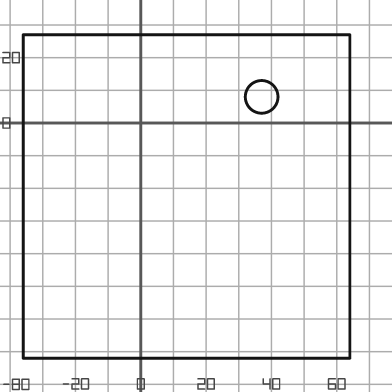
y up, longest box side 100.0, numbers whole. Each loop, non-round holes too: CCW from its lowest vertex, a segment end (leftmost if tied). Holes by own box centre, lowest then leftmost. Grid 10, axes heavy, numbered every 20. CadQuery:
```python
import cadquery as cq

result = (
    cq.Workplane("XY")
    .moveTo(-36.0, -72.0)
    .lineTo(64.0, -72.0)
    .lineTo(64.0, 27.0)
    .lineTo(-36.0, 27.0)
    .close()
    .moveTo(37.0, 8.0)
    .circle(5.0)
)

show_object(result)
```